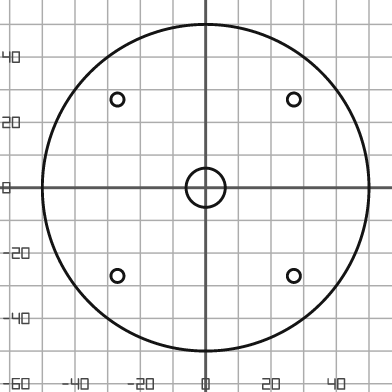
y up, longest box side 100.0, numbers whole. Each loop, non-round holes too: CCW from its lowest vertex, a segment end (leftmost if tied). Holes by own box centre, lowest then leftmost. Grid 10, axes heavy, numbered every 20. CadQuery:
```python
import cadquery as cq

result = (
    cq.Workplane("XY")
    .moveTo(0.0, 0.0)
    .circle(50.0)
    .moveTo(-27.0, -27.0)
    .circle(2.0)
    .moveTo(27.0, -27.0)
    .circle(2.0)
    .moveTo(0.0, 0.0)
    .circle(6.0)
    .moveTo(-27.0, 27.0)
    .circle(2.0)
    .moveTo(27.0, 27.0)
    .circle(2.0)
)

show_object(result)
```